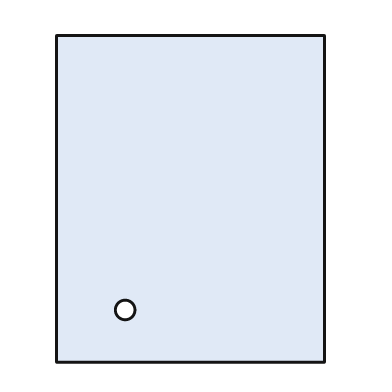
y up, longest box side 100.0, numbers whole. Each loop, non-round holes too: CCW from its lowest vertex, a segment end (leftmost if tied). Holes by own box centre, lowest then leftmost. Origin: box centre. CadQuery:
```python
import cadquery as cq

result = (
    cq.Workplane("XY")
    .moveTo(-41.0, -50.0)
    .lineTo(41.0, -50.0)
    .lineTo(41.0, 50.0)
    .lineTo(-41.0, 50.0)
    .close()
    .moveTo(-20.0, -34.0)
    .circle(3.0)
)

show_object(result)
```